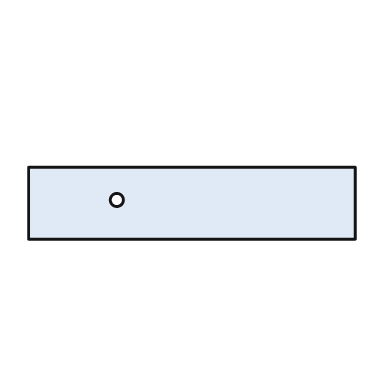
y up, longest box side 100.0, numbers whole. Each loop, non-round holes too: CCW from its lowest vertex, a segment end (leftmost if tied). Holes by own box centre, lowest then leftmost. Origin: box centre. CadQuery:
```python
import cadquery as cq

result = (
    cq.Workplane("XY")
    .moveTo(-50.0, -11.0)
    .lineTo(50.0, -11.0)
    .lineTo(50.0, 11.0)
    .lineTo(-50.0, 11.0)
    .close()
    .moveTo(-23.0, 1.0)
    .circle(2.0)
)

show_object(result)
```